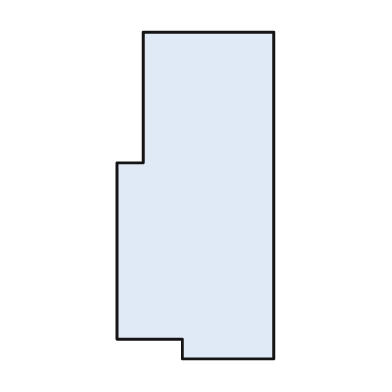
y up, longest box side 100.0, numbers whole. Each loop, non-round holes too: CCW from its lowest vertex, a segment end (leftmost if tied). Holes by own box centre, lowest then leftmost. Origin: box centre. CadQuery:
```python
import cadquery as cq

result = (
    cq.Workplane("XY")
    .moveTo(-4.0, -50.0)
    .lineTo(24.0, -50.0)
    .lineTo(24.0, 50.0)
    .lineTo(-16.0, 50.0)
    .lineTo(-16.0, 10.0)
    .lineTo(-24.0, 10.0)
    .lineTo(-24.0, -44.0)
    .lineTo(-4.0, -44.0)
    .close()
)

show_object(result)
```